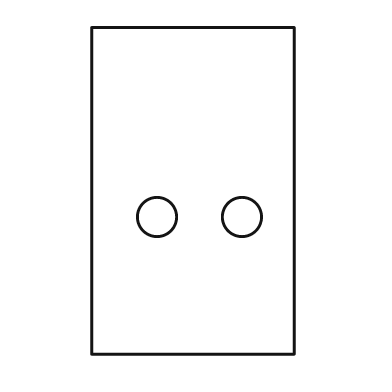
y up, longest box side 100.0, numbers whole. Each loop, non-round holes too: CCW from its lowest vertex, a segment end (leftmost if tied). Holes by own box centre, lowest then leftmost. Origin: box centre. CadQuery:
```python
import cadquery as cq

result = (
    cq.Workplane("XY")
    .moveTo(-31.0, -50.0)
    .lineTo(31.0, -50.0)
    .lineTo(31.0, 50.0)
    .lineTo(-31.0, 50.0)
    .close()
    .moveTo(-11.0, -8.0)
    .circle(6.0)
    .moveTo(15.0, -8.0)
    .circle(6.0)
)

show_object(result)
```